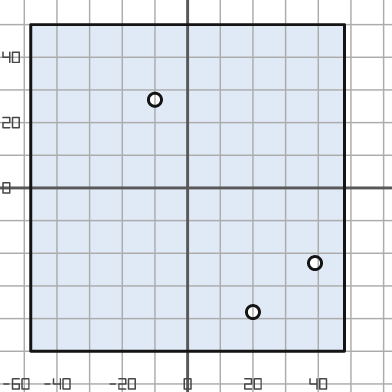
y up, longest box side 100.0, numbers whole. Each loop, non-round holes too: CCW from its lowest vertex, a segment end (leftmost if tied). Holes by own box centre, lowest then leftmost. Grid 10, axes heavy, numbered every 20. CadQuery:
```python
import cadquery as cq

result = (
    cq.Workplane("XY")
    .moveTo(-48.0, -50.0)
    .lineTo(48.0, -50.0)
    .lineTo(48.0, 50.0)
    .lineTo(-48.0, 50.0)
    .close()
    .moveTo(20.0, -38.0)
    .circle(2.0)
    .moveTo(39.0, -23.0)
    .circle(2.0)
    .moveTo(-10.0, 27.0)
    .circle(2.0)
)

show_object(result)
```